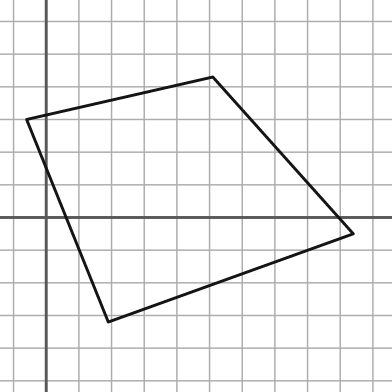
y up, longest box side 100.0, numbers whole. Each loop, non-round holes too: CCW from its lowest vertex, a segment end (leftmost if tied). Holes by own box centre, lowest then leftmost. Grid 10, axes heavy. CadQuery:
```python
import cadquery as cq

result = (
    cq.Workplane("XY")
    .moveTo(19.0, -32.0)
    .lineTo(94.0, -5.0)
    .lineTo(51.0, 43.0)
    .lineTo(-6.0, 30.0)
    .close()
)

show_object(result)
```